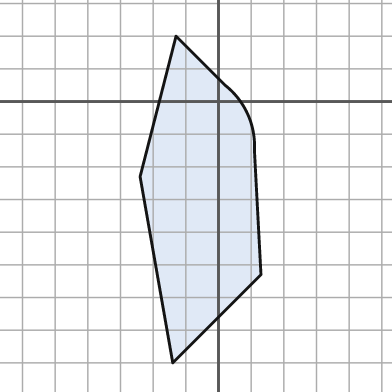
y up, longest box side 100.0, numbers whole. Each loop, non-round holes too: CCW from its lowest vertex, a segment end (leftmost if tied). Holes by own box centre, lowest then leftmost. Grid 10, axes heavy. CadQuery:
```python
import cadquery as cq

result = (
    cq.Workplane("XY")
    .moveTo(-14.0, -80.0)
    .lineTo(13.0, -53.0)
    .lineTo(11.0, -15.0)
    .threePointArc((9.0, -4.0), (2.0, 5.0))
    .lineTo(-13.0, 20.0)
    .lineTo(-24.0, -23.0)
    .close()
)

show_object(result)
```